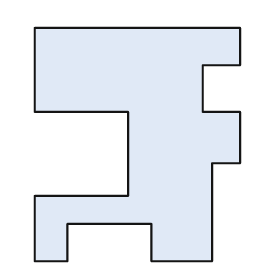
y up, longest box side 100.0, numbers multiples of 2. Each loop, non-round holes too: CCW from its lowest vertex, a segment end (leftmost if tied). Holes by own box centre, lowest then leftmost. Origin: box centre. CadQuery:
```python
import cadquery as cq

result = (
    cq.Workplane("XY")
    .moveTo(-44.0, -50.0)
    .lineTo(-30.0, -50.0)
    .lineTo(-30.0, -34.0)
    .lineTo(6.0, -34.0)
    .lineTo(6.0, -50.0)
    .lineTo(32.0, -50.0)
    .lineTo(32.0, -8.0)
    .lineTo(44.0, -8.0)
    .lineTo(44.0, 14.0)
    .lineTo(28.0, 14.0)
    .lineTo(28.0, 34.0)
    .lineTo(44.0, 34.0)
    .lineTo(44.0, 50.0)
    .lineTo(-44.0, 50.0)
    .lineTo(-44.0, 14.0)
    .lineTo(-4.0, 14.0)
    .lineTo(-4.0, -22.0)
    .lineTo(-44.0, -22.0)
    .close()
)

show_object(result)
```